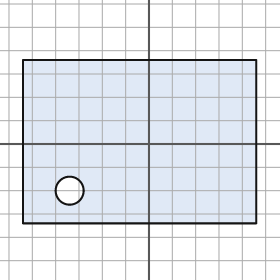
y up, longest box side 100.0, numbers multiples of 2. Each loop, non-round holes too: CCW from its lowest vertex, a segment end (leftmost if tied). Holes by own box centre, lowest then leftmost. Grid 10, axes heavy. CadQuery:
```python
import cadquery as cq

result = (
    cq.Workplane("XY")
    .moveTo(-54.0, -34.0)
    .lineTo(46.0, -34.0)
    .lineTo(46.0, 36.0)
    .lineTo(-54.0, 36.0)
    .close()
    .moveTo(-34.0, -20.0)
    .circle(6.0)
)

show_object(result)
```